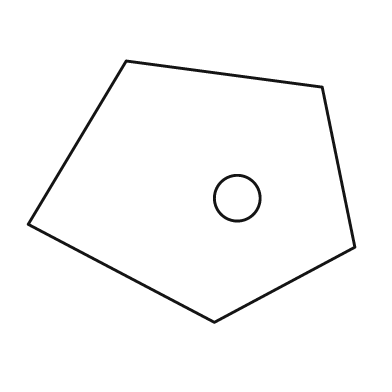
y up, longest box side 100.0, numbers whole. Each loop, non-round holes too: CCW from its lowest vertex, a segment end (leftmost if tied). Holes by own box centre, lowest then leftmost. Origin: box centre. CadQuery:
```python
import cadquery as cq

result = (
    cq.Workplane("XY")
    .moveTo(7.0, -40.0)
    .lineTo(50.0, -17.0)
    .lineTo(40.0, 32.0)
    .lineTo(-20.0, 40.0)
    .lineTo(-50.0, -10.0)
    .close()
    .moveTo(14.0, -2.0)
    .circle(7.0)
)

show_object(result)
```